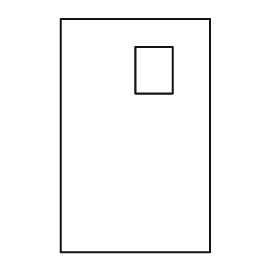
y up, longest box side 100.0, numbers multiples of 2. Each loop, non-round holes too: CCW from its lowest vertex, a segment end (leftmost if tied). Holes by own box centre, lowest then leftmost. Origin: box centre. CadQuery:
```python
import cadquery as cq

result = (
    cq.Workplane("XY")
    .moveTo(-32.0, -50.0)
    .lineTo(32.0, -50.0)
    .lineTo(32.0, 50.0)
    .lineTo(-32.0, 50.0)
    .close()
    .moveTo(0.0, 18.0)
    .lineTo(16.0, 18.0)
    .lineTo(16.0, 38.0)
    .lineTo(0.0, 38.0)
    .close()
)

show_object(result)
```